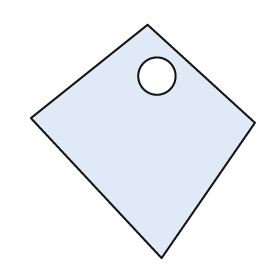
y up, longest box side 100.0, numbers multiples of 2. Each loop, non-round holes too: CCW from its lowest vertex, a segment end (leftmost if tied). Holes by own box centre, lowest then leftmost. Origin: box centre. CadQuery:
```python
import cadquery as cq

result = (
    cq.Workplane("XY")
    .moveTo(8.0, -50.0)
    .lineTo(48.0, 8.0)
    .lineTo(2.0, 50.0)
    .lineTo(-48.0, 10.0)
    .close()
    .moveTo(6.0, 28.0)
    .circle(8.0)
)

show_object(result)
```